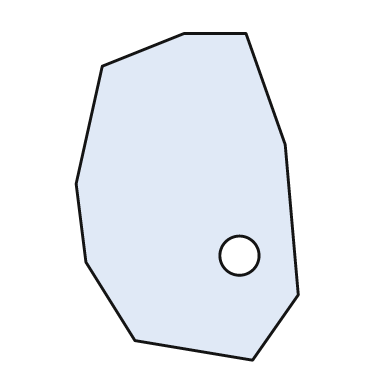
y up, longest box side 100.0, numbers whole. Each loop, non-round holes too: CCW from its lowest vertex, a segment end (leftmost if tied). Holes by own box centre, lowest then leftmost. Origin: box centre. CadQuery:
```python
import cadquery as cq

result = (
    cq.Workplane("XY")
    .moveTo(20.0, -50.0)
    .lineTo(34.0, -30.0)
    .lineTo(30.0, 16.0)
    .lineTo(18.0, 50.0)
    .lineTo(-1.0, 50.0)
    .lineTo(-26.0, 40.0)
    .lineTo(-34.0, 4.0)
    .lineTo(-31.0, -20.0)
    .lineTo(-16.0, -44.0)
    .close()
    .moveTo(16.0, -18.0)
    .circle(6.0)
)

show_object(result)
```